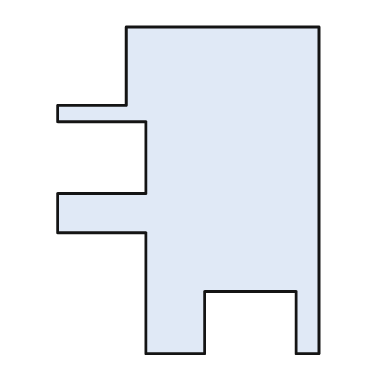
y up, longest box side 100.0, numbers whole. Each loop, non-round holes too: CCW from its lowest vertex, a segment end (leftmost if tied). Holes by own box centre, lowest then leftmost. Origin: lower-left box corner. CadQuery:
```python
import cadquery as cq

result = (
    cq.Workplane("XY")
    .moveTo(27.0, 0.0)
    .lineTo(45.0, 0.0)
    .lineTo(45.0, 19.0)
    .lineTo(73.0, 19.0)
    .lineTo(73.0, 0.0)
    .lineTo(80.0, 0.0)
    .lineTo(80.0, 100.0)
    .lineTo(21.0, 100.0)
    .lineTo(21.0, 76.0)
    .lineTo(0.0, 76.0)
    .lineTo(0.0, 71.0)
    .lineTo(27.0, 71.0)
    .lineTo(27.0, 49.0)
    .lineTo(0.0, 49.0)
    .lineTo(0.0, 37.0)
    .lineTo(27.0, 37.0)
    .close()
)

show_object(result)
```